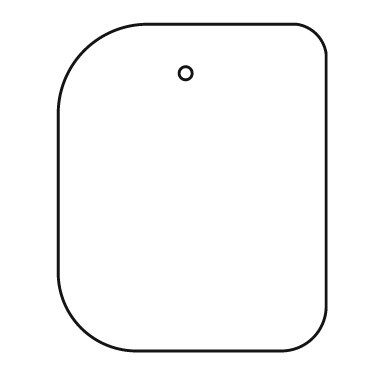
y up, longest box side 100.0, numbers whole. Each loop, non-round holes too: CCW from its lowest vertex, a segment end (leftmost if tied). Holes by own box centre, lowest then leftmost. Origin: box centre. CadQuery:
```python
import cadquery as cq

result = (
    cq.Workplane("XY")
    .moveTo(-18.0, -50.0)
    .lineTo(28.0, -50.0)
    .threePointArc((37.0, -46.0), (41.0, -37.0))
    .lineTo(41.0, 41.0)
    .threePointArc((38.0, 47.0), (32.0, 50.0))
    .lineTo(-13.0, 50.0)
    .threePointArc((-33.0, 42.0), (-41.0, 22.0))
    .lineTo(-41.0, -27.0)
    .threePointArc((-34.0, -43.0), (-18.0, -50.0))
    .close()
    .moveTo(-2.0, 35.0)
    .circle(2.0)
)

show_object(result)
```